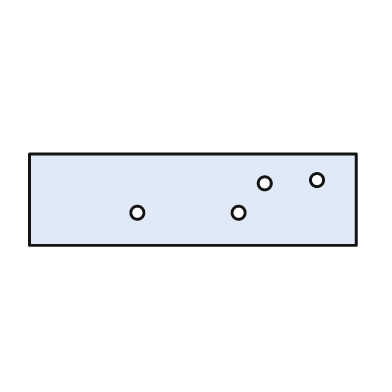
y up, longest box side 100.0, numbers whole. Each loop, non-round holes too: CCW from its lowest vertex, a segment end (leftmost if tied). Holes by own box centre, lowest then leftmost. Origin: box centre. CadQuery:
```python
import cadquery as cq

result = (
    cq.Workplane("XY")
    .moveTo(-50.0, -14.0)
    .lineTo(50.0, -14.0)
    .lineTo(50.0, 14.0)
    .lineTo(-50.0, 14.0)
    .close()
    .moveTo(-17.0, -4.0)
    .circle(2.0)
    .moveTo(14.0, -4.0)
    .circle(2.0)
    .moveTo(22.0, 5.0)
    .circle(2.0)
    .moveTo(38.0, 6.0)
    .circle(2.0)
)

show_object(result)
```